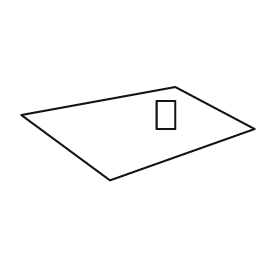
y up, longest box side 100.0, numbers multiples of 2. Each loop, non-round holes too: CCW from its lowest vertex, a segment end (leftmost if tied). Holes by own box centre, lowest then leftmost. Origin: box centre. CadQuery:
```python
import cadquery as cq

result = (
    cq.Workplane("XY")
    .moveTo(-12.0, -20.0)
    .lineTo(50.0, 2.0)
    .lineTo(16.0, 20.0)
    .lineTo(-50.0, 8.0)
    .close()
    .moveTo(8.0, 2.0)
    .lineTo(16.0, 2.0)
    .lineTo(16.0, 14.0)
    .lineTo(8.0, 14.0)
    .close()
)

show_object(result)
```